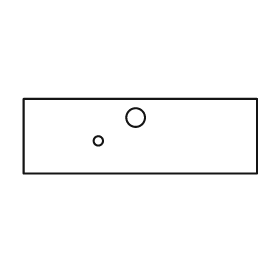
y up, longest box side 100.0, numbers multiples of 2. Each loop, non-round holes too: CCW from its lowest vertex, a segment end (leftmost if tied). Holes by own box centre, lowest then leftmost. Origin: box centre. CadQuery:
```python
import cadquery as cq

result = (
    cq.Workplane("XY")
    .moveTo(-50.0, -16.0)
    .lineTo(50.0, -16.0)
    .lineTo(50.0, 16.0)
    .lineTo(-50.0, 16.0)
    .close()
    .moveTo(-18.0, -2.0)
    .circle(2.0)
    .moveTo(-2.0, 8.0)
    .circle(4.0)
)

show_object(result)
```